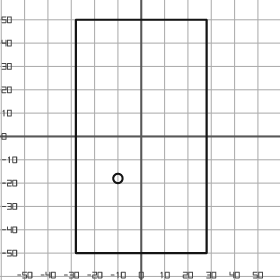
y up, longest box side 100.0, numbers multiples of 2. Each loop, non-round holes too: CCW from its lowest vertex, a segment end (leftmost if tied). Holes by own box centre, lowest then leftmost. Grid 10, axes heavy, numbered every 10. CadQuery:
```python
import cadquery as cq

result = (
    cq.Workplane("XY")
    .moveTo(-28.0, -50.0)
    .lineTo(28.0, -50.0)
    .lineTo(28.0, 50.0)
    .lineTo(-28.0, 50.0)
    .close()
    .moveTo(-10.0, -18.0)
    .circle(2.0)
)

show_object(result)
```